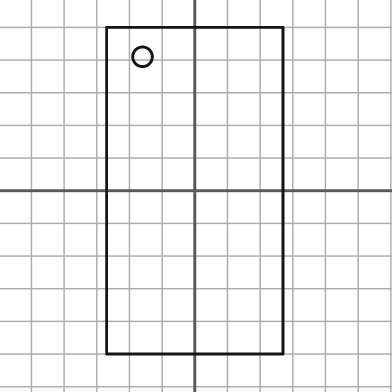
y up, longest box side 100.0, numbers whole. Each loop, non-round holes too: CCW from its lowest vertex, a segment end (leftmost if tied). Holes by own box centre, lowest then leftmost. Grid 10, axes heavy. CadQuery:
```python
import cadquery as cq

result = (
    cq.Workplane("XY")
    .moveTo(-27.0, -50.0)
    .lineTo(27.0, -50.0)
    .lineTo(27.0, 50.0)
    .lineTo(-27.0, 50.0)
    .close()
    .moveTo(-16.0, 41.0)
    .circle(3.0)
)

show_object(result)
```